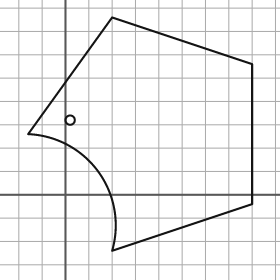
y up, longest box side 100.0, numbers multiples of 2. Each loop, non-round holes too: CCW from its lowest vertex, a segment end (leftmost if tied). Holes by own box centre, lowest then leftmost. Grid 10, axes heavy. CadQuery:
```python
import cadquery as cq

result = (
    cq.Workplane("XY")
    .moveTo(20.0, -24.0)
    .lineTo(80.0, -4.0)
    .lineTo(80.0, 56.0)
    .lineTo(20.0, 76.0)
    .lineTo(-16.0, 26.0)
    .threePointArc((14.0, 10.0), (20.0, -24.0))
    .close()
    .moveTo(2.0, 32.0)
    .circle(2.0)
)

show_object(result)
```